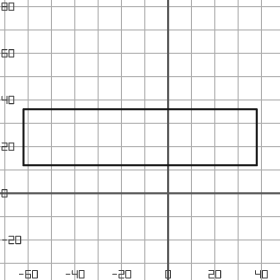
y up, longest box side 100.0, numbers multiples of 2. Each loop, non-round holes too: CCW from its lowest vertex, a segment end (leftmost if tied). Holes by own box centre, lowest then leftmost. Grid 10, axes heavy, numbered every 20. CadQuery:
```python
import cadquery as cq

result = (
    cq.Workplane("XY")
    .moveTo(-62.0, 12.0)
    .lineTo(38.0, 12.0)
    .lineTo(38.0, 36.0)
    .lineTo(-62.0, 36.0)
    .close()
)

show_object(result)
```